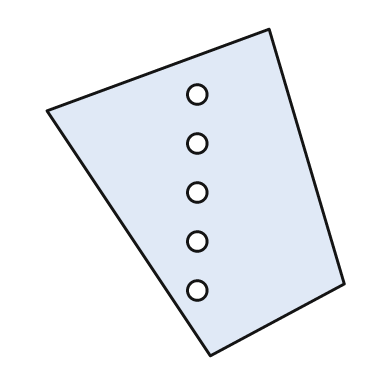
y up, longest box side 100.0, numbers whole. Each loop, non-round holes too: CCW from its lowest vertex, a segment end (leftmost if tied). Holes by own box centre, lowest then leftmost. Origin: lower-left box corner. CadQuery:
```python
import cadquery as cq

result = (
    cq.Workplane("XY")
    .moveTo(50.0, 0.0)
    .lineTo(91.0, 22.0)
    .lineTo(68.0, 100.0)
    .lineTo(0.0, 75.0)
    .close()
    .moveTo(46.0, 20.0)
    .circle(3.0)
    .moveTo(46.0, 35.0)
    .circle(3.0)
    .moveTo(46.0, 50.0)
    .circle(3.0)
    .moveTo(46.0, 65.0)
    .circle(3.0)
    .moveTo(46.0, 80.0)
    .circle(3.0)
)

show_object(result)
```